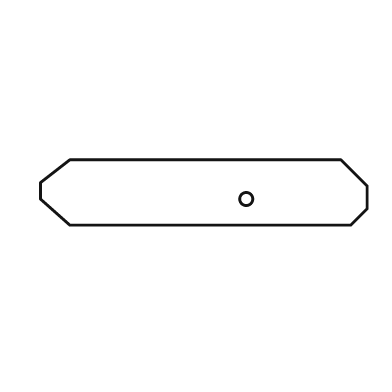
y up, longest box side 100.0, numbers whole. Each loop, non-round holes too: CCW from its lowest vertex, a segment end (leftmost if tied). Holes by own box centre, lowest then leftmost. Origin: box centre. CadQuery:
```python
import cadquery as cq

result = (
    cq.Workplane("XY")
    .moveTo(-41.0, -10.0)
    .lineTo(45.0, -10.0)
    .lineTo(50.0, -5.0)
    .lineTo(50.0, 2.0)
    .lineTo(42.0, 10.0)
    .lineTo(-41.0, 10.0)
    .lineTo(-50.0, 3.0)
    .lineTo(-50.0, -2.0)
    .close()
    .moveTo(13.0, -2.0)
    .circle(2.0)
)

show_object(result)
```